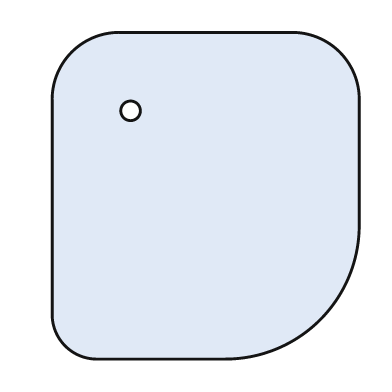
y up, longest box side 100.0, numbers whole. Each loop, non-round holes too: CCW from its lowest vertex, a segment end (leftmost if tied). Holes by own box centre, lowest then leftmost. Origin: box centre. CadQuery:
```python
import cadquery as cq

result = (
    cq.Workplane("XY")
    .moveTo(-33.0, -50.0)
    .lineTo(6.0, -50.0)
    .threePointArc((35.0, -38.0), (47.0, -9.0))
    .lineTo(47.0, 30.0)
    .threePointArc((41.0, 44.0), (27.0, 50.0))
    .lineTo(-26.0, 50.0)
    .threePointArc((-41.0, 44.0), (-47.0, 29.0))
    .lineTo(-47.0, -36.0)
    .threePointArc((-43.0, -46.0), (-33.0, -50.0))
    .close()
    .moveTo(-23.0, 26.0)
    .circle(3.0)
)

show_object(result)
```